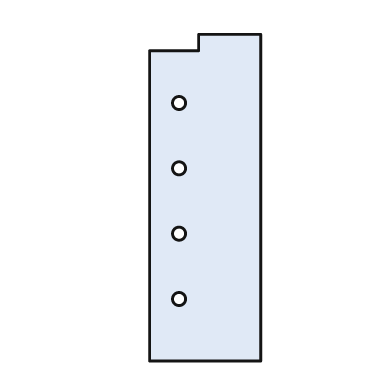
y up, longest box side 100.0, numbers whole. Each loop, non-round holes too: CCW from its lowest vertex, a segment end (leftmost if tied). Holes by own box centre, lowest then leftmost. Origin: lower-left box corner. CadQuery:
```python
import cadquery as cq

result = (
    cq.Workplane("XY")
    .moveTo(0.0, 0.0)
    .lineTo(34.0, 0.0)
    .lineTo(34.0, 100.0)
    .lineTo(15.0, 100.0)
    .lineTo(15.0, 95.0)
    .lineTo(0.0, 95.0)
    .close()
    .moveTo(9.0, 19.0)
    .circle(2.0)
    .moveTo(9.0, 39.0)
    .circle(2.0)
    .moveTo(9.0, 59.0)
    .circle(2.0)
    .moveTo(9.0, 79.0)
    .circle(2.0)
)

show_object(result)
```